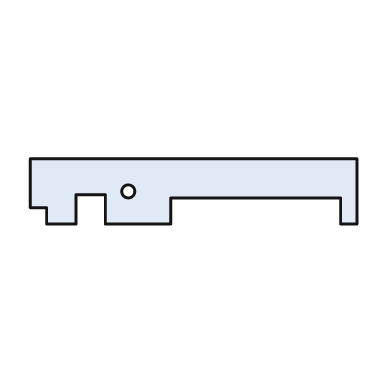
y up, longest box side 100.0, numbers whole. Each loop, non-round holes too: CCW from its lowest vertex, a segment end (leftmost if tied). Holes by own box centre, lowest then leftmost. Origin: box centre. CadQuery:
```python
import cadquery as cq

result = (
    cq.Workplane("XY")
    .moveTo(-45.0, -10.0)
    .lineTo(-36.0, -10.0)
    .lineTo(-36.0, -1.0)
    .lineTo(-27.0, -1.0)
    .lineTo(-27.0, -10.0)
    .lineTo(-7.0, -10.0)
    .lineTo(-7.0, -2.0)
    .lineTo(45.0, -2.0)
    .lineTo(45.0, -10.0)
    .lineTo(50.0, -10.0)
    .lineTo(50.0, 10.0)
    .lineTo(-50.0, 10.0)
    .lineTo(-50.0, -5.0)
    .lineTo(-45.0, -5.0)
    .close()
    .moveTo(-20.0, 0.0)
    .circle(2.0)
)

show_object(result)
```